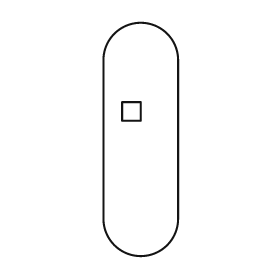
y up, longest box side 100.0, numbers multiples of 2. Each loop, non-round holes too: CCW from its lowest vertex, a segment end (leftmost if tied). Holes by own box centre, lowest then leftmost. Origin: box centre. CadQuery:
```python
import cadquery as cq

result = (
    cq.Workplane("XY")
    .moveTo(-16.0, -34.0)
    .threePointArc((0.0, -50.0), (16.0, -34.0))
    .lineTo(16.0, 34.0)
    .threePointArc((0.0, 50.0), (-16.0, 34.0))
    .close()
    .moveTo(-8.0, 8.0)
    .lineTo(0.0, 8.0)
    .lineTo(0.0, 16.0)
    .lineTo(-8.0, 16.0)
    .close()
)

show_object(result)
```